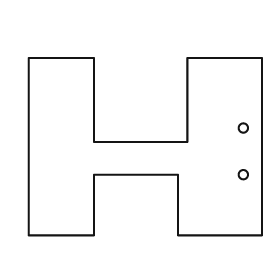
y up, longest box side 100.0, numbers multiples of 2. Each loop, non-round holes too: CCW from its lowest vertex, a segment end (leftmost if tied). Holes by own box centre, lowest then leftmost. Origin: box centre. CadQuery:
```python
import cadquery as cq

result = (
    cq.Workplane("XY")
    .moveTo(-50.0, -38.0)
    .lineTo(-22.0, -38.0)
    .lineTo(-22.0, -12.0)
    .lineTo(14.0, -12.0)
    .lineTo(14.0, -38.0)
    .lineTo(50.0, -38.0)
    .lineTo(50.0, 38.0)
    .lineTo(18.0, 38.0)
    .lineTo(18.0, 2.0)
    .lineTo(-22.0, 2.0)
    .lineTo(-22.0, 38.0)
    .lineTo(-50.0, 38.0)
    .close()
    .moveTo(42.0, -12.0)
    .circle(2.0)
    .moveTo(42.0, 8.0)
    .circle(2.0)
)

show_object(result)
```